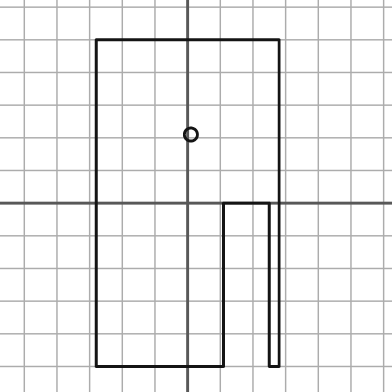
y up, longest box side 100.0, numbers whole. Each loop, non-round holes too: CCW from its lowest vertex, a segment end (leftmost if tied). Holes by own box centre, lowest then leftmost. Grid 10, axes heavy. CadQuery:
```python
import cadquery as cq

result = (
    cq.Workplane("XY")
    .moveTo(-28.0, -50.0)
    .lineTo(11.0, -50.0)
    .lineTo(11.0, 0.0)
    .lineTo(25.0, 0.0)
    .lineTo(25.0, -50.0)
    .lineTo(28.0, -50.0)
    .lineTo(28.0, 50.0)
    .lineTo(-28.0, 50.0)
    .close()
    .moveTo(1.0, 21.0)
    .circle(2.0)
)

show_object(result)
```